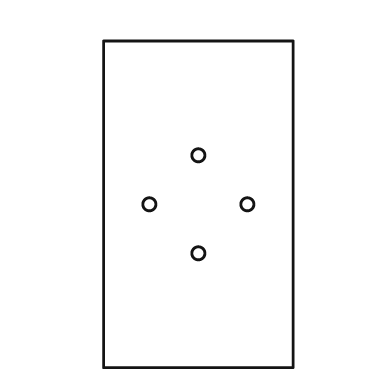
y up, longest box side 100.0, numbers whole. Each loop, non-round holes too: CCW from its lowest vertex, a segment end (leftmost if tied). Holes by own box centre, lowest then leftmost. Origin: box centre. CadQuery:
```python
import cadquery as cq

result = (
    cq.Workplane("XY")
    .moveTo(-29.0, -50.0)
    .lineTo(29.0, -50.0)
    .lineTo(29.0, 50.0)
    .lineTo(-29.0, 50.0)
    .close()
    .moveTo(0.0, -15.0)
    .circle(2.0)
    .moveTo(-15.0, 0.0)
    .circle(2.0)
    .moveTo(15.0, 0.0)
    .circle(2.0)
    .moveTo(0.0, 15.0)
    .circle(2.0)
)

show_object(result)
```